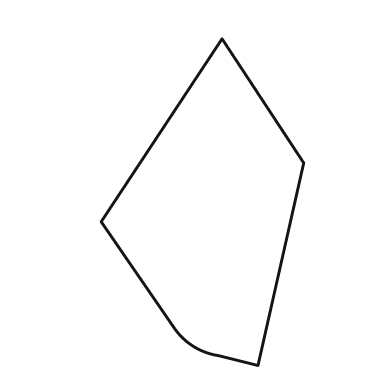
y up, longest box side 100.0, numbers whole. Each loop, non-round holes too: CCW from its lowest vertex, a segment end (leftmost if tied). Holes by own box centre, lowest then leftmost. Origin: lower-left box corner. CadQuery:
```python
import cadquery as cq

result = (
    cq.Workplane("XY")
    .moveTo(48.0, 0.0)
    .lineTo(62.0, 62.0)
    .lineTo(37.0, 100.0)
    .lineTo(0.0, 44.0)
    .lineTo(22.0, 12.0)
    .threePointArc((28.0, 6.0), (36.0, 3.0))
    .close()
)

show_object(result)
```